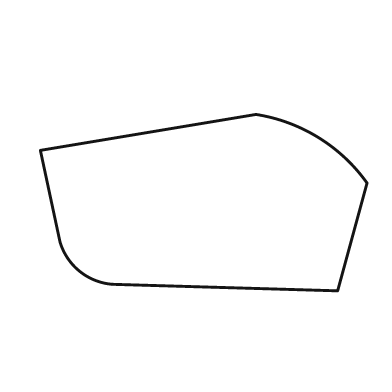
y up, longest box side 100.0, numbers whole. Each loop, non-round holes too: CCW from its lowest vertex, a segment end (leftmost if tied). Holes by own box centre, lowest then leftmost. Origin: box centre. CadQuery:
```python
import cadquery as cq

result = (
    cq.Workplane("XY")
    .moveTo(41.0, -27.0)
    .lineTo(50.0, 6.0)
    .threePointArc((35.0, 20.0), (16.0, 27.0))
    .lineTo(-50.0, 16.0)
    .lineTo(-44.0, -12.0)
    .threePointArc((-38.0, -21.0), (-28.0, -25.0))
    .close()
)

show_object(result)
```